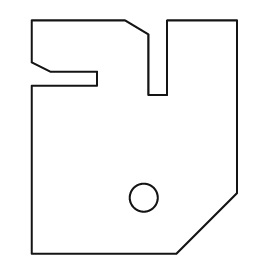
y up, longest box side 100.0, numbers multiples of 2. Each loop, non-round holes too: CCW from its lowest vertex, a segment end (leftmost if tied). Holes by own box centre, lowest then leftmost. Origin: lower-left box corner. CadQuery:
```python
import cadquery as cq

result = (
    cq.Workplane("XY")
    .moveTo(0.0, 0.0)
    .lineTo(62.0, 0.0)
    .lineTo(88.0, 26.0)
    .lineTo(88.0, 100.0)
    .lineTo(58.0, 100.0)
    .lineTo(58.0, 68.0)
    .lineTo(50.0, 68.0)
    .lineTo(50.0, 94.0)
    .lineTo(40.0, 100.0)
    .lineTo(0.0, 100.0)
    .lineTo(0.0, 82.0)
    .lineTo(8.0, 78.0)
    .lineTo(28.0, 78.0)
    .lineTo(28.0, 72.0)
    .lineTo(0.0, 72.0)
    .close()
    .moveTo(48.0, 24.0)
    .circle(6.0)
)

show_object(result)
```